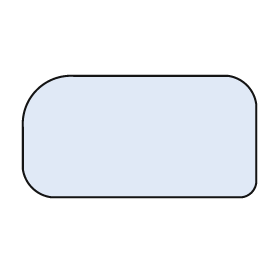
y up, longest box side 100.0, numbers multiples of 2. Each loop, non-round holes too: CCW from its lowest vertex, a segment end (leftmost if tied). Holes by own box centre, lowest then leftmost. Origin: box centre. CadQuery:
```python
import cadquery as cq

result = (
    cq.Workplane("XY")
    .moveTo(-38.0, -26.0)
    .lineTo(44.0, -26.0)
    .threePointArc((48.0, -24.0), (50.0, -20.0))
    .lineTo(50.0, 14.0)
    .threePointArc((46.0, 22.0), (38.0, 26.0))
    .lineTo(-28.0, 26.0)
    .threePointArc((-44.0, 20.0), (-50.0, 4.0))
    .lineTo(-50.0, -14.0)
    .threePointArc((-46.0, -22.0), (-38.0, -26.0))
    .close()
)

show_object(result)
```